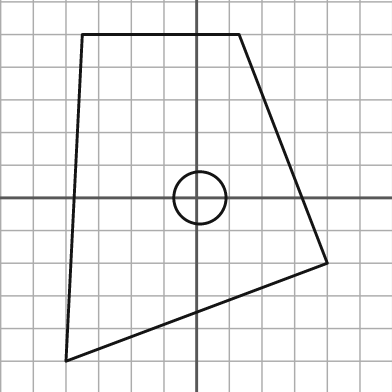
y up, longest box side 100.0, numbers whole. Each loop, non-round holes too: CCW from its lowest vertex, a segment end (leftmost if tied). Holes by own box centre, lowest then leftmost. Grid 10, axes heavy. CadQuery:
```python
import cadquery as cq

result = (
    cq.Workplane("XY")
    .moveTo(-40.0, -50.0)
    .lineTo(40.0, -20.0)
    .lineTo(13.0, 50.0)
    .lineTo(-35.0, 50.0)
    .close()
    .moveTo(1.0, 0.0)
    .circle(8.0)
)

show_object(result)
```